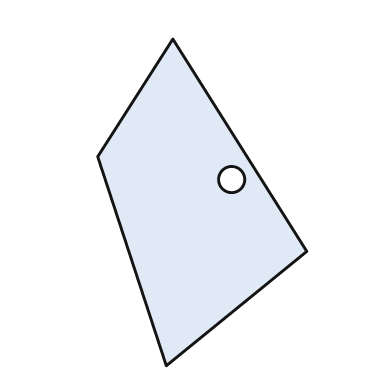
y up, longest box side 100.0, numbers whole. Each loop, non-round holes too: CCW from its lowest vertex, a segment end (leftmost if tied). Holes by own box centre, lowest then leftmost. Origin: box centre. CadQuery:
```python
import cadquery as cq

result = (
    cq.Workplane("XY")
    .moveTo(-11.0, -50.0)
    .lineTo(32.0, -15.0)
    .lineTo(-9.0, 50.0)
    .lineTo(-32.0, 14.0)
    .close()
    .moveTo(9.0, 7.0)
    .circle(4.0)
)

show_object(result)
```